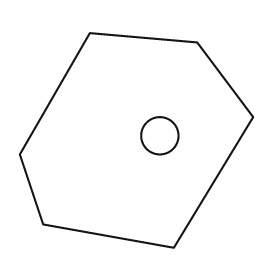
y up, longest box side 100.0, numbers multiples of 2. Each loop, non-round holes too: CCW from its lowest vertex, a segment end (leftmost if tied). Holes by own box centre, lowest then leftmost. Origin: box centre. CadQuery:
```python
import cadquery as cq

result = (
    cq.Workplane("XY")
    .moveTo(16.0, -46.0)
    .lineTo(50.0, 10.0)
    .lineTo(26.0, 42.0)
    .lineTo(-20.0, 46.0)
    .lineTo(-50.0, -6.0)
    .lineTo(-40.0, -36.0)
    .close()
    .moveTo(10.0, 2.0)
    .circle(8.0)
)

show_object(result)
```